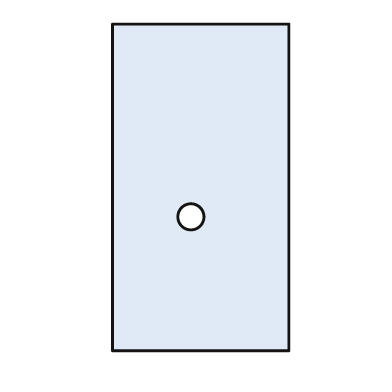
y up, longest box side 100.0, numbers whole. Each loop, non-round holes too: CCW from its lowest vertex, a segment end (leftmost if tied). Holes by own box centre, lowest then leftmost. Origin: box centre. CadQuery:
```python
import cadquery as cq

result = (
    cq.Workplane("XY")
    .moveTo(-27.0, -50.0)
    .lineTo(27.0, -50.0)
    .lineTo(27.0, 50.0)
    .lineTo(-27.0, 50.0)
    .close()
    .moveTo(-3.0, -9.0)
    .circle(4.0)
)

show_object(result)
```